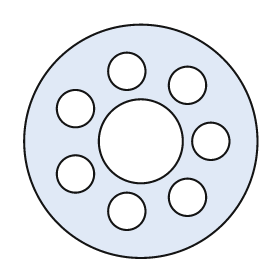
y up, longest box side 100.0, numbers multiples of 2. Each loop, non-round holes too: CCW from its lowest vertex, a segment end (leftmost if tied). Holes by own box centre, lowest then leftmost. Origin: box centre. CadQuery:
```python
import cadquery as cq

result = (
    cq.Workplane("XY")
    .moveTo(0.0, 0.0)
    .circle(50.0)
    .moveTo(-6.0, -30.0)
    .circle(8.0)
    .moveTo(20.0, -24.0)
    .circle(8.0)
    .moveTo(-28.0, -14.0)
    .circle(8.0)
    .moveTo(0.0, 0.0)
    .circle(18.0)
    .moveTo(30.0, 0.0)
    .circle(8.0)
    .moveTo(-28.0, 14.0)
    .circle(8.0)
    .moveTo(20.0, 24.0)
    .circle(8.0)
    .moveTo(-6.0, 30.0)
    .circle(8.0)
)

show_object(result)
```